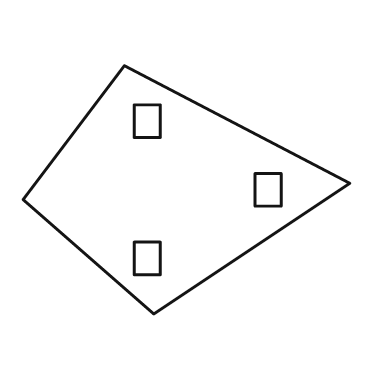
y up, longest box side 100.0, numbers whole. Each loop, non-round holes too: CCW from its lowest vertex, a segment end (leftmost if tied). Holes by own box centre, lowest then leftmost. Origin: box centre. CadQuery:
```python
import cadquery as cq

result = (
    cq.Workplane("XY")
    .moveTo(-10.0, -38.0)
    .lineTo(50.0, 2.0)
    .lineTo(-19.0, 38.0)
    .lineTo(-50.0, -3.0)
    .close()
    .moveTo(-16.0, -26.0)
    .lineTo(-8.0, -26.0)
    .lineTo(-8.0, -16.0)
    .lineTo(-16.0, -16.0)
    .close()
    .moveTo(21.0, -5.0)
    .lineTo(29.0, -5.0)
    .lineTo(29.0, 5.0)
    .lineTo(21.0, 5.0)
    .close()
    .moveTo(-16.0, 16.0)
    .lineTo(-8.0, 16.0)
    .lineTo(-8.0, 26.0)
    .lineTo(-16.0, 26.0)
    .close()
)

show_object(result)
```